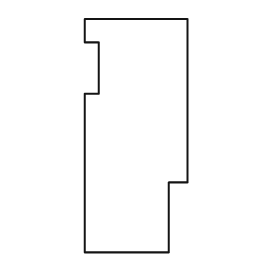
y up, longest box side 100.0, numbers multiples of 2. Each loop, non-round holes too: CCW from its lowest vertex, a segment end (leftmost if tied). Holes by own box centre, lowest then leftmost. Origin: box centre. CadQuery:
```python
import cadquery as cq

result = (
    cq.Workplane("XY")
    .moveTo(-22.0, -50.0)
    .lineTo(14.0, -50.0)
    .lineTo(14.0, -20.0)
    .lineTo(22.0, -20.0)
    .lineTo(22.0, 50.0)
    .lineTo(-22.0, 50.0)
    .lineTo(-22.0, 40.0)
    .lineTo(-16.0, 40.0)
    .lineTo(-16.0, 18.0)
    .lineTo(-22.0, 18.0)
    .close()
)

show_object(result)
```